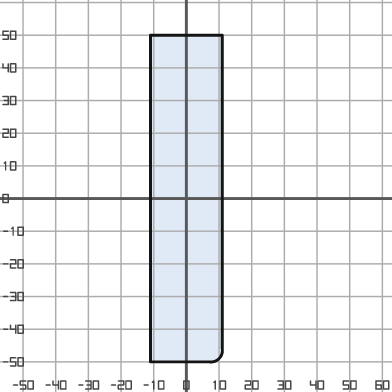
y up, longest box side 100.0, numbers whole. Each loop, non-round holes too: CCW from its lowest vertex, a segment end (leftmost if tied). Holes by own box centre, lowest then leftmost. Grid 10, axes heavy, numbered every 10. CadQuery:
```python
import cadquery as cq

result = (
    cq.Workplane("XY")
    .moveTo(-11.0, -50.0)
    .lineTo(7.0, -50.0)
    .threePointArc((10.0, -49.0), (11.0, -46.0))
    .lineTo(11.0, 50.0)
    .lineTo(-11.0, 50.0)
    .close()
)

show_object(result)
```